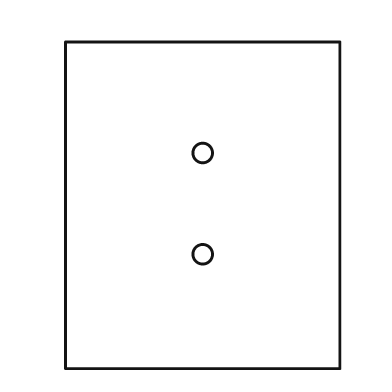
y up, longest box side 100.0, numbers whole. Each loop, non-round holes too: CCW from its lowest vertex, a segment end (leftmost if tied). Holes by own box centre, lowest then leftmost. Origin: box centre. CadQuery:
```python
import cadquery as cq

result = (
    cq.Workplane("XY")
    .moveTo(-42.0, -50.0)
    .lineTo(42.0, -50.0)
    .lineTo(42.0, 50.0)
    .lineTo(-42.0, 50.0)
    .close()
    .moveTo(0.0, -15.0)
    .circle(3.0)
    .moveTo(0.0, 16.0)
    .circle(3.0)
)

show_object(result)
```